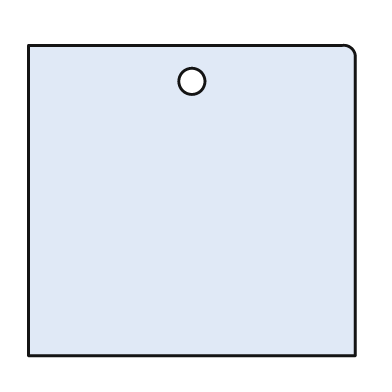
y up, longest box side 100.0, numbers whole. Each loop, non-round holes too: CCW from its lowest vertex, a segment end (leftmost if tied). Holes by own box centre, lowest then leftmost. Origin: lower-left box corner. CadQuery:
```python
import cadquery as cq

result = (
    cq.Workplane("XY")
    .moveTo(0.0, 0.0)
    .lineTo(100.0, 0.0)
    .lineTo(100.0, 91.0)
    .threePointArc((99.0, 94.0), (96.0, 95.0))
    .lineTo(0.0, 95.0)
    .close()
    .moveTo(50.0, 84.0)
    .circle(4.0)
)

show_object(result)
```